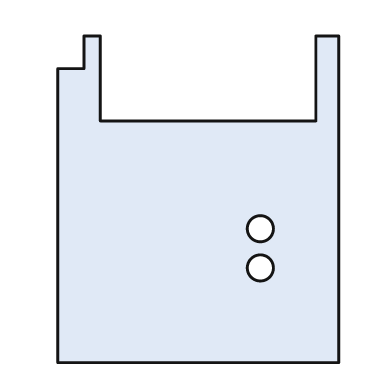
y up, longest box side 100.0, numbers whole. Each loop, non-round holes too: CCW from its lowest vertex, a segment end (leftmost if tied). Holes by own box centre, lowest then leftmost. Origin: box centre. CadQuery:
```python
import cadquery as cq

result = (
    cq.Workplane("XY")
    .moveTo(-43.0, -50.0)
    .lineTo(43.0, -50.0)
    .lineTo(43.0, 50.0)
    .lineTo(36.0, 50.0)
    .lineTo(36.0, 24.0)
    .lineTo(-30.0, 24.0)
    .lineTo(-30.0, 50.0)
    .lineTo(-35.0, 50.0)
    .lineTo(-35.0, 40.0)
    .lineTo(-43.0, 40.0)
    .close()
    .moveTo(19.0, -21.0)
    .circle(4.0)
    .moveTo(19.0, -9.0)
    .circle(4.0)
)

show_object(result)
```